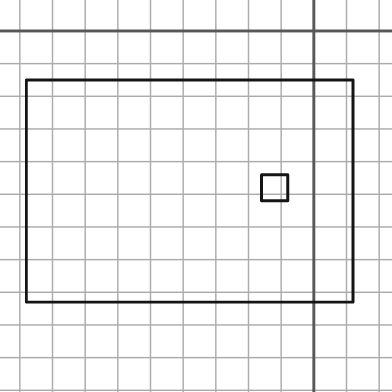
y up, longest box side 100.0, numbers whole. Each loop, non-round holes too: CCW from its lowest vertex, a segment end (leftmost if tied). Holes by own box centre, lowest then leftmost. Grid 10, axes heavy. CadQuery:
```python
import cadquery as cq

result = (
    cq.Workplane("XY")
    .moveTo(-88.0, -83.0)
    .lineTo(12.0, -83.0)
    .lineTo(12.0, -15.0)
    .lineTo(-88.0, -15.0)
    .close()
    .moveTo(-16.0, -52.0)
    .lineTo(-8.0, -52.0)
    .lineTo(-8.0, -44.0)
    .lineTo(-16.0, -44.0)
    .close()
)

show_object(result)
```